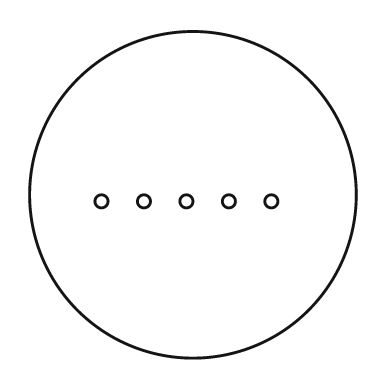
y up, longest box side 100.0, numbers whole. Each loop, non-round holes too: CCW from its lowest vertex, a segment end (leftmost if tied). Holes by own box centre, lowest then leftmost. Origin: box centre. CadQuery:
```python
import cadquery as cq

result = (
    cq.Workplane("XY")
    .moveTo(0.0, 0.0)
    .circle(50.0)
    .moveTo(-28.0, -2.0)
    .circle(2.0)
    .moveTo(-15.0, -2.0)
    .circle(2.0)
    .moveTo(-2.0, -2.0)
    .circle(2.0)
    .moveTo(11.0, -2.0)
    .circle(2.0)
    .moveTo(24.0, -2.0)
    .circle(2.0)
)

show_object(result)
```